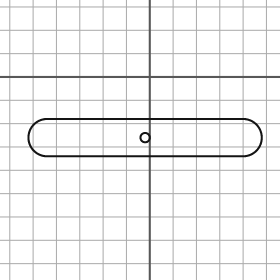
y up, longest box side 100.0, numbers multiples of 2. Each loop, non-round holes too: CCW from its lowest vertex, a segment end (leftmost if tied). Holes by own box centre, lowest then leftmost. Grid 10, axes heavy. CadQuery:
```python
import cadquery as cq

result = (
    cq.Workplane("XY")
    .moveTo(-44.0, -34.0)
    .lineTo(40.0, -34.0)
    .threePointArc((48.0, -26.0), (40.0, -18.0))
    .lineTo(-44.0, -18.0)
    .threePointArc((-52.0, -26.0), (-44.0, -34.0))
    .close()
    .moveTo(-2.0, -26.0)
    .circle(2.0)
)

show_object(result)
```